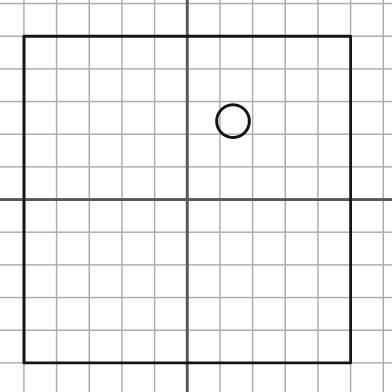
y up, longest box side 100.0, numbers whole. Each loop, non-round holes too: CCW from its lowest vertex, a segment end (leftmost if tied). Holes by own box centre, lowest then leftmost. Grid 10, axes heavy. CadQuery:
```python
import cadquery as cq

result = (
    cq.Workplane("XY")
    .moveTo(-50.0, -50.0)
    .lineTo(50.0, -50.0)
    .lineTo(50.0, 50.0)
    .lineTo(-50.0, 50.0)
    .close()
    .moveTo(14.0, 24.0)
    .circle(5.0)
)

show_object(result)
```